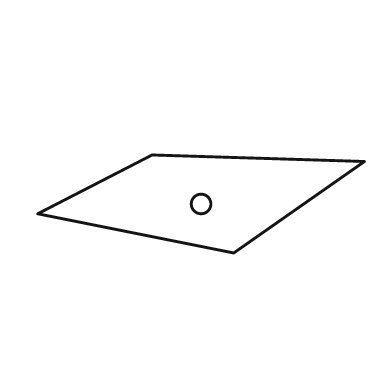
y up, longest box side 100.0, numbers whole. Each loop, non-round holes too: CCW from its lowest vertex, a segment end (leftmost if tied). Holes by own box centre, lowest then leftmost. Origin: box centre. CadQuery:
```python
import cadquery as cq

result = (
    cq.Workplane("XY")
    .moveTo(10.0, -15.0)
    .lineTo(50.0, 13.0)
    .lineTo(-15.0, 15.0)
    .lineTo(-50.0, -3.0)
    .close()
    .moveTo(0.0, 0.0)
    .circle(3.0)
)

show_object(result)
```